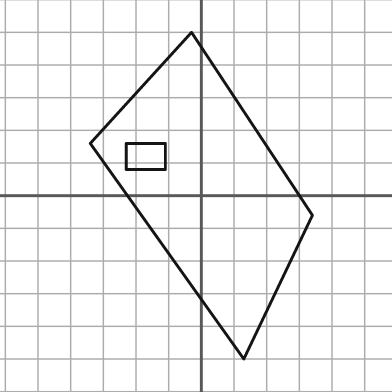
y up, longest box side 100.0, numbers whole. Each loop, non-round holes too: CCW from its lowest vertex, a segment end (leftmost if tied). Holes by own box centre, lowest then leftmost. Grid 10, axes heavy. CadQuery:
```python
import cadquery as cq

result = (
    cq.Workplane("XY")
    .moveTo(13.0, -50.0)
    .lineTo(34.0, -6.0)
    .lineTo(-3.0, 50.0)
    .lineTo(-34.0, 16.0)
    .close()
    .moveTo(-23.0, 8.0)
    .lineTo(-11.0, 8.0)
    .lineTo(-11.0, 16.0)
    .lineTo(-23.0, 16.0)
    .close()
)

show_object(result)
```